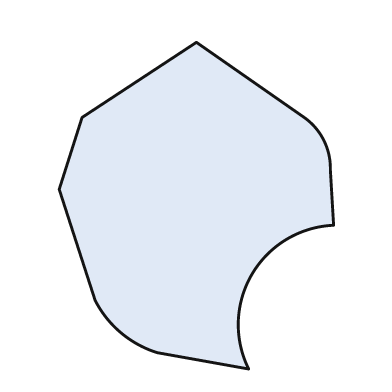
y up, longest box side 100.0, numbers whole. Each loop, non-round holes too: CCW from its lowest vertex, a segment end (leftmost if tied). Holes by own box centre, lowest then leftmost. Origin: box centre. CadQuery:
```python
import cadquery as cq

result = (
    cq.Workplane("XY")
    .moveTo(16.0, -50.0)
    .threePointArc((17.0, -21.0), (42.0, -6.0))
    .lineTo(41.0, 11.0)
    .threePointArc((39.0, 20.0), (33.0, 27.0))
    .lineTo(0.0, 50.0)
    .lineTo(-35.0, 27.0)
    .lineTo(-42.0, 5.0)
    .lineTo(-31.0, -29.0)
    .threePointArc((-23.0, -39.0), (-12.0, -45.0))
    .close()
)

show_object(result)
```